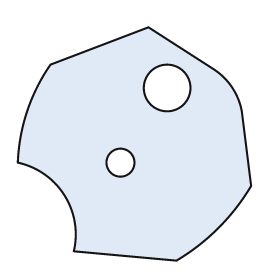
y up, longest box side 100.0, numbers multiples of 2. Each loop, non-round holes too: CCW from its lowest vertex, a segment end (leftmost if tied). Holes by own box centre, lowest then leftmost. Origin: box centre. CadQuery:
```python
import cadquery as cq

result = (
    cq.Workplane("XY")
    .moveTo(18.0, -50.0)
    .threePointArc((36.0, -36.0), (50.0, -18.0))
    .lineTo(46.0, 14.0)
    .threePointArc((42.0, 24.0), (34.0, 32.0))
    .lineTo(6.0, 50.0)
    .lineTo(-36.0, 34.0)
    .threePointArc((-46.0, 14.0), (-50.0, -8.0))
    .threePointArc((-30.0, -22.0), (-26.0, -46.0))
    .close()
    .moveTo(-6.0, -8.0)
    .circle(6.0)
    .moveTo(14.0, 24.0)
    .circle(10.0)
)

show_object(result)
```